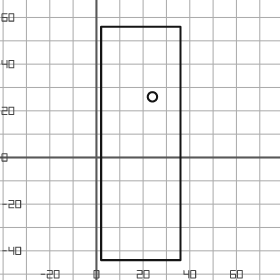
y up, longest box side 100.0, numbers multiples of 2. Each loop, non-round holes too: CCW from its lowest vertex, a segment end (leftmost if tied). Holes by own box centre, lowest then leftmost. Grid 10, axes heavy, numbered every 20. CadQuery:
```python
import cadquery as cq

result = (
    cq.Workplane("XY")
    .moveTo(2.0, -44.0)
    .lineTo(36.0, -44.0)
    .lineTo(36.0, 56.0)
    .lineTo(2.0, 56.0)
    .close()
    .moveTo(24.0, 26.0)
    .circle(2.0)
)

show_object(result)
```